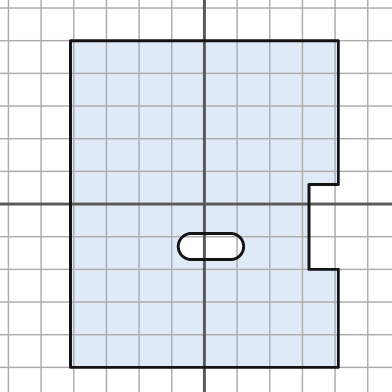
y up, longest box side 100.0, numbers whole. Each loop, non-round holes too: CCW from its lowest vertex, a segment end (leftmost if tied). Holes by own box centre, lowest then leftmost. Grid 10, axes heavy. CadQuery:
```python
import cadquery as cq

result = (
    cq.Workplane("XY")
    .moveTo(-41.0, -50.0)
    .lineTo(41.0, -50.0)
    .lineTo(41.0, -20.0)
    .lineTo(32.0, -20.0)
    .lineTo(32.0, 6.0)
    .lineTo(41.0, 6.0)
    .lineTo(41.0, 50.0)
    .lineTo(-41.0, 50.0)
    .close()
    .moveTo(-4.0, -17.0)
    .lineTo(8.0, -17.0)
    .threePointArc((12.0, -13.0), (8.0, -9.0))
    .lineTo(-4.0, -9.0)
    .threePointArc((-8.0, -13.0), (-4.0, -17.0))
    .close()
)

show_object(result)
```